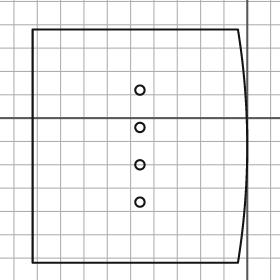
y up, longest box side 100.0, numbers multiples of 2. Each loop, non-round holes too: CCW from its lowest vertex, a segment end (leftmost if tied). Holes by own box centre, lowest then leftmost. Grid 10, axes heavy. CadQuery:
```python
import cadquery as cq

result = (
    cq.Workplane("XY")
    .moveTo(-92.0, -62.0)
    .lineTo(-4.0, -62.0)
    .threePointArc((0.0, -12.0), (-4.0, 38.0))
    .lineTo(-92.0, 38.0)
    .close()
    .moveTo(-46.0, -36.0)
    .circle(2.0)
    .moveTo(-46.0, -20.0)
    .circle(2.0)
    .moveTo(-46.0, -4.0)
    .circle(2.0)
    .moveTo(-46.0, 12.0)
    .circle(2.0)
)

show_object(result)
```